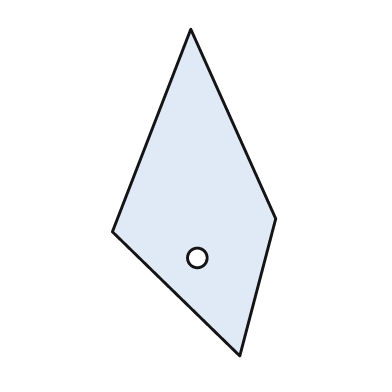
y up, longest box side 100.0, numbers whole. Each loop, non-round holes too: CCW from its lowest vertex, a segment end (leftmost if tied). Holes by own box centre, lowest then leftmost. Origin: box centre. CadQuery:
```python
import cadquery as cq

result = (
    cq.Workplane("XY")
    .moveTo(14.0, -50.0)
    .lineTo(25.0, -8.0)
    .lineTo(-1.0, 50.0)
    .lineTo(-25.0, -12.0)
    .close()
    .moveTo(1.0, -20.0)
    .circle(3.0)
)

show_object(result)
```